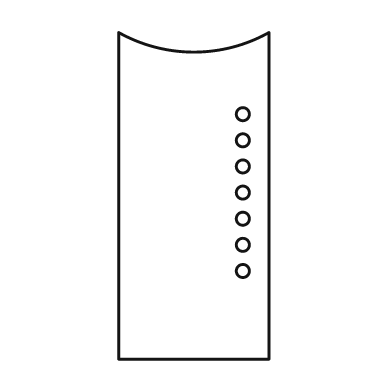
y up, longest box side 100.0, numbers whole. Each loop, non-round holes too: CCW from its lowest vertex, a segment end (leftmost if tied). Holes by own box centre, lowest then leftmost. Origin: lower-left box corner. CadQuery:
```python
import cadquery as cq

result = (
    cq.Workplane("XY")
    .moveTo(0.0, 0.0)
    .lineTo(46.0, 0.0)
    .lineTo(46.0, 100.0)
    .threePointArc((23.0, 94.0), (0.0, 100.0))
    .close()
    .moveTo(38.0, 27.0)
    .circle(2.0)
    .moveTo(38.0, 35.0)
    .circle(2.0)
    .moveTo(38.0, 43.0)
    .circle(2.0)
    .moveTo(38.0, 51.0)
    .circle(2.0)
    .moveTo(38.0, 59.0)
    .circle(2.0)
    .moveTo(38.0, 67.0)
    .circle(2.0)
    .moveTo(38.0, 75.0)
    .circle(2.0)
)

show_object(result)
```